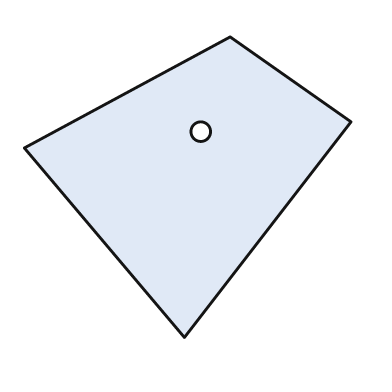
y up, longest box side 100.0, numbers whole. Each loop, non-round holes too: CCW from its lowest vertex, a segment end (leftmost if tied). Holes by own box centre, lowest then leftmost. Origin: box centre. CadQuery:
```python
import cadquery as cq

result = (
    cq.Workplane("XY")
    .moveTo(-1.0, -46.0)
    .lineTo(50.0, 20.0)
    .lineTo(13.0, 46.0)
    .lineTo(-50.0, 12.0)
    .close()
    .moveTo(4.0, 17.0)
    .circle(3.0)
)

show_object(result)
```